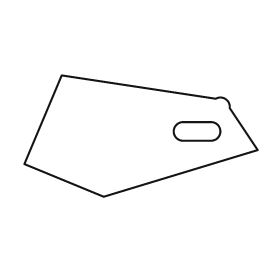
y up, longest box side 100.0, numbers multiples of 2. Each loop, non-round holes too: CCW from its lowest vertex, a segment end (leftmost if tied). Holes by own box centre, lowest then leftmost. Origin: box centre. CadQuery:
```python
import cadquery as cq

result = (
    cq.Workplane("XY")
    .moveTo(-16.0, -26.0)
    .lineTo(50.0, -6.0)
    .lineTo(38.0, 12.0)
    .threePointArc((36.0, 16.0), (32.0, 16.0))
    .lineTo(-34.0, 26.0)
    .lineTo(-50.0, -12.0)
    .close()
    .moveTo(18.0, -2.0)
    .lineTo(30.0, -2.0)
    .threePointArc((34.0, 2.0), (30.0, 6.0))
    .lineTo(18.0, 6.0)
    .threePointArc((14.0, 2.0), (18.0, -2.0))
    .close()
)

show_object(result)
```